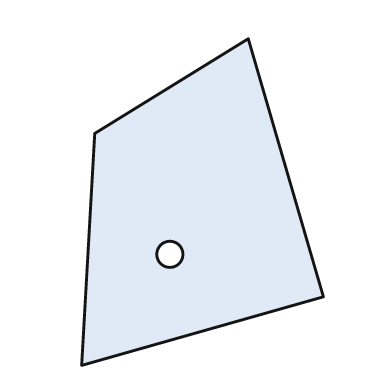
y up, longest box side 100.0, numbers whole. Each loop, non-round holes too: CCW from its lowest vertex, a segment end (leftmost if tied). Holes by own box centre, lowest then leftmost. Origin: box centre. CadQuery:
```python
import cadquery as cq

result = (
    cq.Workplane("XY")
    .moveTo(-37.0, -50.0)
    .lineTo(37.0, -29.0)
    .lineTo(14.0, 50.0)
    .lineTo(-33.0, 21.0)
    .close()
    .moveTo(-10.0, -16.0)
    .circle(4.0)
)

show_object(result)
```